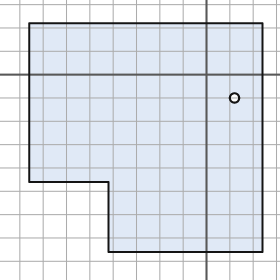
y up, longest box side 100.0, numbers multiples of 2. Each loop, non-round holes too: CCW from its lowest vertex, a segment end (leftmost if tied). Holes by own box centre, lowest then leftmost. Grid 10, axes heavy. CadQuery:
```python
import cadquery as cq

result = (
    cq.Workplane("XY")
    .moveTo(-42.0, -76.0)
    .lineTo(24.0, -76.0)
    .lineTo(24.0, 22.0)
    .lineTo(-76.0, 22.0)
    .lineTo(-76.0, -46.0)
    .lineTo(-42.0, -46.0)
    .close()
    .moveTo(12.0, -10.0)
    .circle(2.0)
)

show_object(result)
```